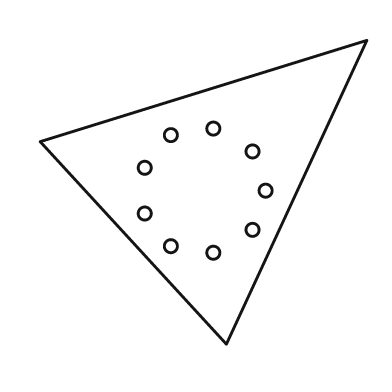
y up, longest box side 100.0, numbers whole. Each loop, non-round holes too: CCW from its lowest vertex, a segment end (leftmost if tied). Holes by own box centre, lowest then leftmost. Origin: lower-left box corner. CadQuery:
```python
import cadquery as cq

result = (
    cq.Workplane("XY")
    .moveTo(57.0, 0.0)
    .lineTo(100.0, 93.0)
    .lineTo(0.0, 62.0)
    .close()
    .moveTo(53.0, 28.0)
    .circle(2.0)
    .moveTo(40.0, 30.0)
    .circle(2.0)
    .moveTo(65.0, 35.0)
    .circle(2.0)
    .moveTo(32.0, 40.0)
    .circle(2.0)
    .moveTo(69.0, 47.0)
    .circle(2.0)
    .moveTo(32.0, 54.0)
    .circle(2.0)
    .moveTo(65.0, 59.0)
    .circle(2.0)
    .moveTo(40.0, 64.0)
    .circle(2.0)
    .moveTo(53.0, 66.0)
    .circle(2.0)
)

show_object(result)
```